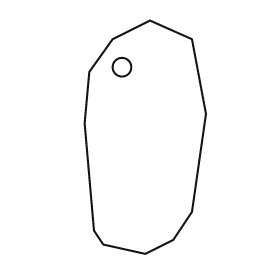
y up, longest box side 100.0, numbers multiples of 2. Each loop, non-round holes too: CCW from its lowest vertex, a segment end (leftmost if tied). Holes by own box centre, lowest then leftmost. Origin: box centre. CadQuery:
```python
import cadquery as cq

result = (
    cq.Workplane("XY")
    .moveTo(0.0, -50.0)
    .lineTo(12.0, -44.0)
    .lineTo(20.0, -32.0)
    .lineTo(26.0, 10.0)
    .lineTo(20.0, 42.0)
    .lineTo(2.0, 50.0)
    .lineTo(-14.0, 42.0)
    .lineTo(-24.0, 28.0)
    .lineTo(-26.0, 6.0)
    .lineTo(-22.0, -40.0)
    .lineTo(-18.0, -46.0)
    .close()
    .moveTo(-10.0, 30.0)
    .circle(4.0)
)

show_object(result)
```